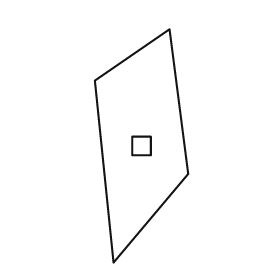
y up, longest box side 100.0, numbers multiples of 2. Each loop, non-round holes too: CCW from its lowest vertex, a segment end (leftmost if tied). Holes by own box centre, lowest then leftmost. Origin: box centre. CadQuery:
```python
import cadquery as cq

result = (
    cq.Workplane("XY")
    .moveTo(-12.0, -50.0)
    .lineTo(20.0, -12.0)
    .lineTo(12.0, 50.0)
    .lineTo(-20.0, 28.0)
    .close()
    .moveTo(-4.0, -4.0)
    .lineTo(4.0, -4.0)
    .lineTo(4.0, 4.0)
    .lineTo(-4.0, 4.0)
    .close()
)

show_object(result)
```